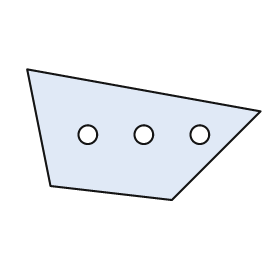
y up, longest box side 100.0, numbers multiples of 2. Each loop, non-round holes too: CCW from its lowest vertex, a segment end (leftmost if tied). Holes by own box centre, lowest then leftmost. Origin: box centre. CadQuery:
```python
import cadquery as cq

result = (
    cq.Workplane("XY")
    .moveTo(12.0, -28.0)
    .lineTo(50.0, 10.0)
    .lineTo(-50.0, 28.0)
    .lineTo(-40.0, -22.0)
    .close()
    .moveTo(-24.0, 0.0)
    .circle(4.0)
    .moveTo(0.0, 0.0)
    .circle(4.0)
    .moveTo(24.0, 0.0)
    .circle(4.0)
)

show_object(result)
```